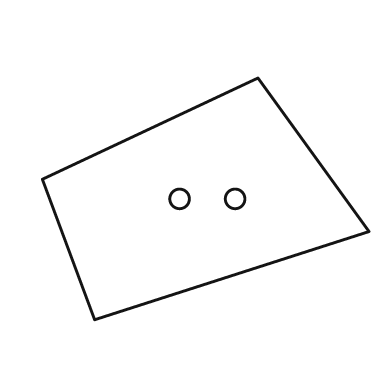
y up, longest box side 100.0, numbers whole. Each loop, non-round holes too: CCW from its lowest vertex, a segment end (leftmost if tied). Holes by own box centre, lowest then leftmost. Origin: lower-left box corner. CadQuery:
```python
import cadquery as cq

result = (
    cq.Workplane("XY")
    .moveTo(16.0, 0.0)
    .lineTo(100.0, 27.0)
    .lineTo(66.0, 74.0)
    .lineTo(0.0, 43.0)
    .close()
    .moveTo(42.0, 37.0)
    .circle(3.0)
    .moveTo(59.0, 37.0)
    .circle(3.0)
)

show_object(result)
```